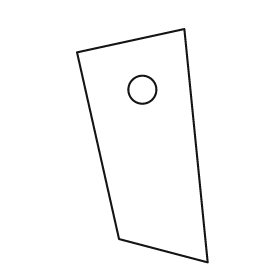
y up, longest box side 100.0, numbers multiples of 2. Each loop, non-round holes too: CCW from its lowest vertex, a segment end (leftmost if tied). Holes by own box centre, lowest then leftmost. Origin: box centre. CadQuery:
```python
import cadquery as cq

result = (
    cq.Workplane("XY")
    .moveTo(28.0, -50.0)
    .lineTo(18.0, 50.0)
    .lineTo(-28.0, 40.0)
    .lineTo(-10.0, -40.0)
    .close()
    .moveTo(0.0, 24.0)
    .circle(6.0)
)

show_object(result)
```